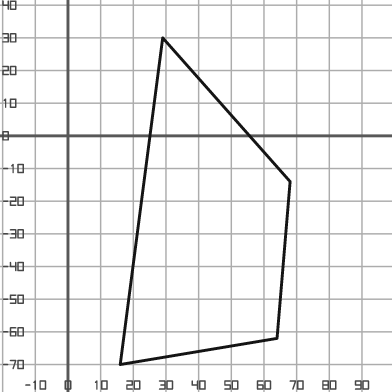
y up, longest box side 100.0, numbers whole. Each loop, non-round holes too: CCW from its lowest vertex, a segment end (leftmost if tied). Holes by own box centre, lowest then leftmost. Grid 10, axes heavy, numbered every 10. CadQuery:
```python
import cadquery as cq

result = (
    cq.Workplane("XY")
    .moveTo(16.0, -70.0)
    .lineTo(64.0, -62.0)
    .lineTo(68.0, -14.0)
    .lineTo(29.0, 30.0)
    .close()
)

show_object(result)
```